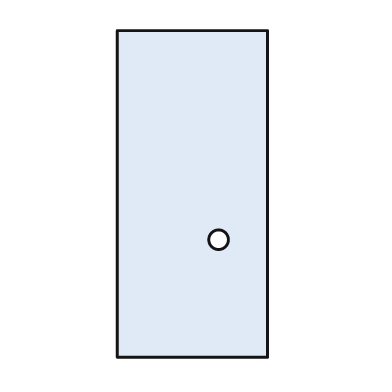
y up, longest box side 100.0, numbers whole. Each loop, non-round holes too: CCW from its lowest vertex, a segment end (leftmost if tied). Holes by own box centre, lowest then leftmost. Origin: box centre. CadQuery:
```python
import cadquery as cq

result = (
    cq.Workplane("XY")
    .moveTo(-23.0, -50.0)
    .lineTo(23.0, -50.0)
    .lineTo(23.0, 50.0)
    .lineTo(-23.0, 50.0)
    .close()
    .moveTo(8.0, -14.0)
    .circle(3.0)
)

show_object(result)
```